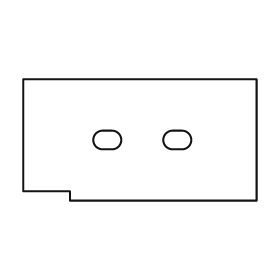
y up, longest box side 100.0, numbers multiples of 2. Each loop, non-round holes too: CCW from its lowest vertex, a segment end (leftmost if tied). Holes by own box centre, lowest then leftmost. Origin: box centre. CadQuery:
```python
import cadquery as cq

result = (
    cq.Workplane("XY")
    .moveTo(-30.0, -26.0)
    .lineTo(50.0, -26.0)
    .lineTo(50.0, 26.0)
    .lineTo(-50.0, 26.0)
    .lineTo(-50.0, -22.0)
    .lineTo(-30.0, -22.0)
    .close()
    .moveTo(-16.0, -4.0)
    .lineTo(-12.0, -4.0)
    .threePointArc((-8.0, 0.0), (-12.0, 4.0))
    .lineTo(-16.0, 4.0)
    .threePointArc((-20.0, 0.0), (-16.0, -4.0))
    .close()
    .moveTo(14.0, -4.0)
    .lineTo(18.0, -4.0)
    .threePointArc((22.0, 0.0), (18.0, 4.0))
    .lineTo(14.0, 4.0)
    .threePointArc((10.0, 0.0), (14.0, -4.0))
    .close()
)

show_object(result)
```